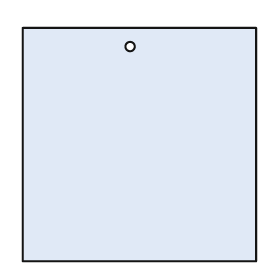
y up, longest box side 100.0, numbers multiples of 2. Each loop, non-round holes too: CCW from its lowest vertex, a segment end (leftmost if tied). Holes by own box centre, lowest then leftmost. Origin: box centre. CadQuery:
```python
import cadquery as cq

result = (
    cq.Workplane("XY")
    .moveTo(-50.0, -50.0)
    .lineTo(50.0, -50.0)
    .lineTo(50.0, 50.0)
    .lineTo(-50.0, 50.0)
    .close()
    .moveTo(-4.0, 42.0)
    .circle(2.0)
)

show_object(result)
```